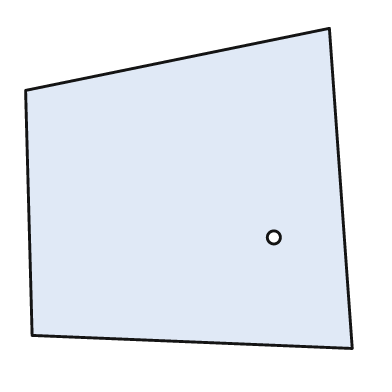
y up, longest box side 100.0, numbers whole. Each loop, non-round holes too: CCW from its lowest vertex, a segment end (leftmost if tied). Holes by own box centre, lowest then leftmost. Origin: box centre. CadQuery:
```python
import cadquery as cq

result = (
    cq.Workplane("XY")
    .moveTo(50.0, -49.0)
    .lineTo(43.0, 49.0)
    .lineTo(-50.0, 30.0)
    .lineTo(-48.0, -45.0)
    .close()
    .moveTo(26.0, -15.0)
    .circle(2.0)
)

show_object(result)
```